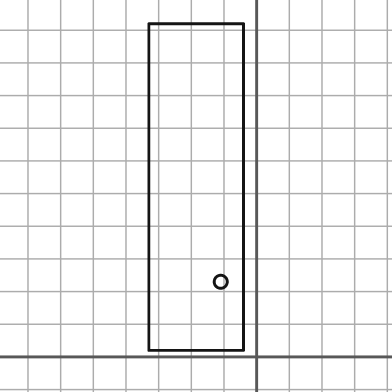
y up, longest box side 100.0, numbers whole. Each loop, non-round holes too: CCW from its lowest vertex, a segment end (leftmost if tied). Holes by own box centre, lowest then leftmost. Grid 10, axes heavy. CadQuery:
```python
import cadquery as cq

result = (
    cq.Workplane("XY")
    .moveTo(-33.0, 2.0)
    .lineTo(-4.0, 2.0)
    .lineTo(-4.0, 102.0)
    .lineTo(-33.0, 102.0)
    .close()
    .moveTo(-11.0, 23.0)
    .circle(2.0)
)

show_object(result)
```